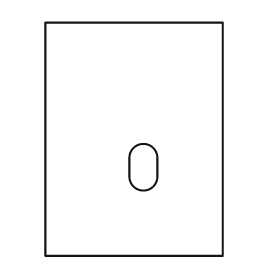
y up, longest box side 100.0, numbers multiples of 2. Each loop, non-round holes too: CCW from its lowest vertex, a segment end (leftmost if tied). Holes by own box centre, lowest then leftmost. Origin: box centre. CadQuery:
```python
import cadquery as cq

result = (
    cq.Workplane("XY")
    .moveTo(-38.0, -50.0)
    .lineTo(38.0, -50.0)
    .lineTo(38.0, 50.0)
    .lineTo(-38.0, 50.0)
    .close()
    .moveTo(-2.0, -16.0)
    .threePointArc((4.0, -22.0), (10.0, -16.0))
    .lineTo(10.0, -8.0)
    .threePointArc((4.0, -2.0), (-2.0, -8.0))
    .close()
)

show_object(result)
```